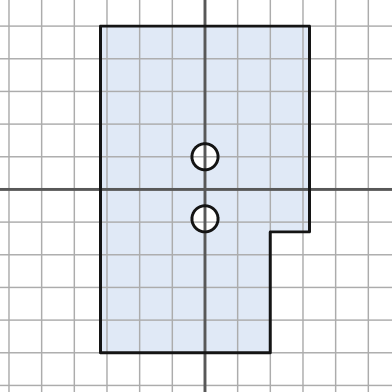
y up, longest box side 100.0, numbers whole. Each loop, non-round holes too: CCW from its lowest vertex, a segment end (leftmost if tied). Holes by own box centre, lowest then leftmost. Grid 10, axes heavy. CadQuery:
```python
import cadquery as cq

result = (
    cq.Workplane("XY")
    .moveTo(-32.0, -50.0)
    .lineTo(20.0, -50.0)
    .lineTo(20.0, -13.0)
    .lineTo(32.0, -13.0)
    .lineTo(32.0, 50.0)
    .lineTo(-32.0, 50.0)
    .close()
    .moveTo(0.0, -9.0)
    .circle(4.0)
    .moveTo(0.0, 10.0)
    .circle(4.0)
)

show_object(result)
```